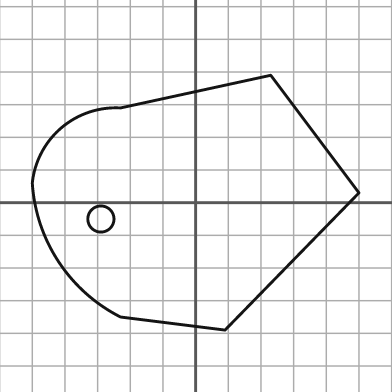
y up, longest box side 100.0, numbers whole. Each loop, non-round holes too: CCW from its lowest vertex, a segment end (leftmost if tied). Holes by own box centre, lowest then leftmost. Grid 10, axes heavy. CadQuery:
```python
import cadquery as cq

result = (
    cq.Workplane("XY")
    .moveTo(9.0, -39.0)
    .lineTo(50.0, 3.0)
    .lineTo(23.0, 39.0)
    .lineTo(-23.0, 29.0)
    .threePointArc((-41.0, 23.0), (-50.0, 6.0))
    .threePointArc((-42.0, -18.0), (-23.0, -35.0))
    .close()
    .moveTo(-29.0, -5.0)
    .circle(4.0)
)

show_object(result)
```